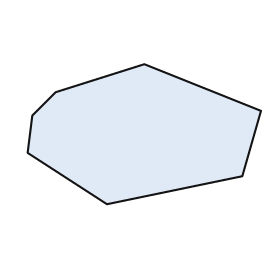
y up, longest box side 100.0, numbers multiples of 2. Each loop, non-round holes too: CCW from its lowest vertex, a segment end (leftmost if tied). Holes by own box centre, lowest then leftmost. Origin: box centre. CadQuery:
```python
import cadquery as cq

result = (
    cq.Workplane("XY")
    .moveTo(-16.0, -30.0)
    .lineTo(42.0, -18.0)
    .lineTo(50.0, 10.0)
    .lineTo(0.0, 30.0)
    .lineTo(-38.0, 18.0)
    .lineTo(-48.0, 8.0)
    .lineTo(-50.0, -8.0)
    .close()
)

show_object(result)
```